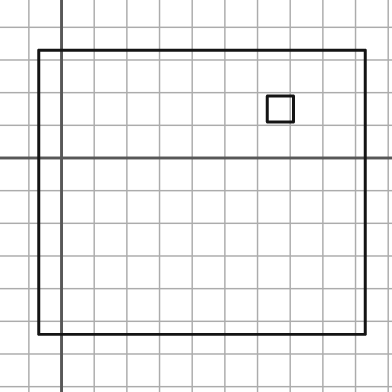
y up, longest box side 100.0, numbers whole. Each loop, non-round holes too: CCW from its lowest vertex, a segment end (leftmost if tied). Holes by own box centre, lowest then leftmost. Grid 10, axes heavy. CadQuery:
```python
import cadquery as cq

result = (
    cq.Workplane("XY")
    .moveTo(-7.0, -54.0)
    .lineTo(93.0, -54.0)
    .lineTo(93.0, 33.0)
    .lineTo(-7.0, 33.0)
    .close()
    .moveTo(63.0, 11.0)
    .lineTo(71.0, 11.0)
    .lineTo(71.0, 19.0)
    .lineTo(63.0, 19.0)
    .close()
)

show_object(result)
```